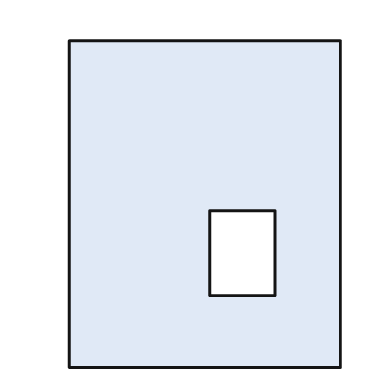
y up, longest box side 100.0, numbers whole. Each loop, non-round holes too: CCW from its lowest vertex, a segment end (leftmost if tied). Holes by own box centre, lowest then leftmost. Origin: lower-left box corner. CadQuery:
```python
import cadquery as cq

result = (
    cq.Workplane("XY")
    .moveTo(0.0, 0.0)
    .lineTo(83.0, 0.0)
    .lineTo(83.0, 100.0)
    .lineTo(0.0, 100.0)
    .close()
    .moveTo(43.0, 22.0)
    .lineTo(63.0, 22.0)
    .lineTo(63.0, 48.0)
    .lineTo(43.0, 48.0)
    .close()
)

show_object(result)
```